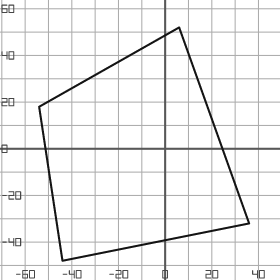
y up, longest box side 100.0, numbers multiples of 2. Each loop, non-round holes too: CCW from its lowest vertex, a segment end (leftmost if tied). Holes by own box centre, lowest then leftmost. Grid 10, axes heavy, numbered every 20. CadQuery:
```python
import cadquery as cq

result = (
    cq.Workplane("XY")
    .moveTo(-44.0, -48.0)
    .lineTo(36.0, -32.0)
    .lineTo(6.0, 52.0)
    .lineTo(-54.0, 18.0)
    .close()
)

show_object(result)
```